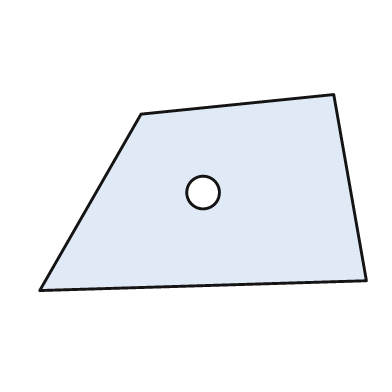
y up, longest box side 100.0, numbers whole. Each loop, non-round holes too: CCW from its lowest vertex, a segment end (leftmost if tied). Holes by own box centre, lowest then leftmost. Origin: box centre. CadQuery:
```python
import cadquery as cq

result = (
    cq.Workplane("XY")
    .moveTo(-50.0, -30.0)
    .lineTo(50.0, -27.0)
    .lineTo(40.0, 30.0)
    .lineTo(-19.0, 24.0)
    .close()
    .moveTo(0.0, 0.0)
    .circle(5.0)
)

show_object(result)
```